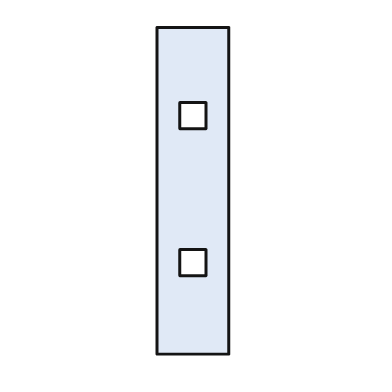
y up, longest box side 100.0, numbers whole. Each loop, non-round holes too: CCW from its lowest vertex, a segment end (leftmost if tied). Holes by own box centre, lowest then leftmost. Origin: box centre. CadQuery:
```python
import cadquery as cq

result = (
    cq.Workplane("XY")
    .moveTo(-11.0, -50.0)
    .lineTo(11.0, -50.0)
    .lineTo(11.0, 50.0)
    .lineTo(-11.0, 50.0)
    .close()
    .moveTo(-4.0, -26.0)
    .lineTo(4.0, -26.0)
    .lineTo(4.0, -18.0)
    .lineTo(-4.0, -18.0)
    .close()
    .moveTo(-4.0, 19.0)
    .lineTo(4.0, 19.0)
    .lineTo(4.0, 27.0)
    .lineTo(-4.0, 27.0)
    .close()
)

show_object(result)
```